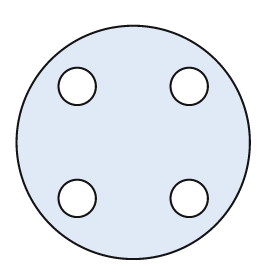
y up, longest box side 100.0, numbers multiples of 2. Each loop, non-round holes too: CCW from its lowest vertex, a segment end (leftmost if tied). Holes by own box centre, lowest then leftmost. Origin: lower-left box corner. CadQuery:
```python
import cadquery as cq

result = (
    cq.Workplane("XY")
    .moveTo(50.0, 50.0)
    .circle(50.0)
    .moveTo(26.0, 26.0)
    .circle(8.0)
    .moveTo(74.0, 26.0)
    .circle(8.0)
    .moveTo(26.0, 74.0)
    .circle(8.0)
    .moveTo(74.0, 74.0)
    .circle(8.0)
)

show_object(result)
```